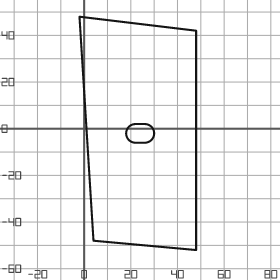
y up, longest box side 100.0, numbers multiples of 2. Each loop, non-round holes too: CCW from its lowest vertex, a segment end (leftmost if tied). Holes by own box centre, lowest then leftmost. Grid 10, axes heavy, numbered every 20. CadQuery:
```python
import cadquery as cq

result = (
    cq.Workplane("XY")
    .moveTo(48.0, -52.0)
    .lineTo(48.0, 42.0)
    .lineTo(-2.0, 48.0)
    .lineTo(4.0, -48.0)
    .close()
    .moveTo(22.0, -6.0)
    .lineTo(26.0, -6.0)
    .threePointArc((30.0, -2.0), (26.0, 2.0))
    .lineTo(22.0, 2.0)
    .threePointArc((18.0, -2.0), (22.0, -6.0))
    .close()
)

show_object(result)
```